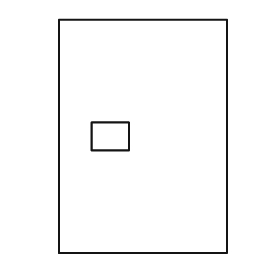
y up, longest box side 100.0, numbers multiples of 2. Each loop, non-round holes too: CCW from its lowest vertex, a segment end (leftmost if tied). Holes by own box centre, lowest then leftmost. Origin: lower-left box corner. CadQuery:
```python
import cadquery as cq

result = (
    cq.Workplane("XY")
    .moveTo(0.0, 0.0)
    .lineTo(72.0, 0.0)
    .lineTo(72.0, 100.0)
    .lineTo(0.0, 100.0)
    .close()
    .moveTo(14.0, 44.0)
    .lineTo(30.0, 44.0)
    .lineTo(30.0, 56.0)
    .lineTo(14.0, 56.0)
    .close()
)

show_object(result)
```